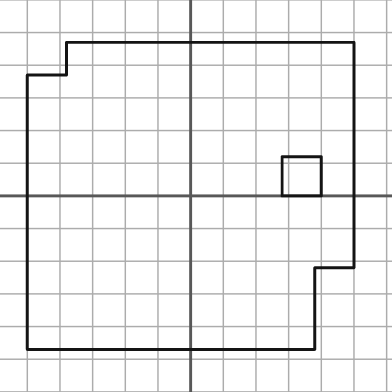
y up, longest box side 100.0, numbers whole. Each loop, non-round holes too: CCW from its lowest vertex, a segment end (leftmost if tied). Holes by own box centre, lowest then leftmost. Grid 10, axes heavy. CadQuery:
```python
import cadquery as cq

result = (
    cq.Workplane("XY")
    .moveTo(-50.0, -47.0)
    .lineTo(38.0, -47.0)
    .lineTo(38.0, -22.0)
    .lineTo(50.0, -22.0)
    .lineTo(50.0, 47.0)
    .lineTo(-38.0, 47.0)
    .lineTo(-38.0, 37.0)
    .lineTo(-50.0, 37.0)
    .close()
    .moveTo(28.0, 0.0)
    .lineTo(40.0, 0.0)
    .lineTo(40.0, 12.0)
    .lineTo(28.0, 12.0)
    .close()
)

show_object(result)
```